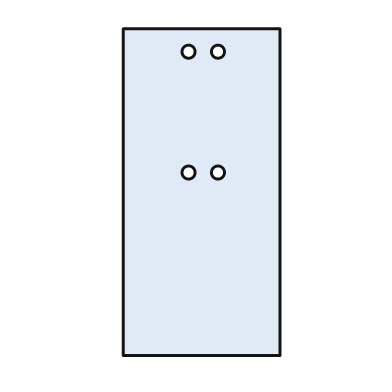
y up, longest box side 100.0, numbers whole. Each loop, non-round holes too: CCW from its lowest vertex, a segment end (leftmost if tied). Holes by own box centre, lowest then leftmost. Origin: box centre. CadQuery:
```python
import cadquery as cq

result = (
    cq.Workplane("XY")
    .moveTo(-24.0, -50.0)
    .lineTo(24.0, -50.0)
    .lineTo(24.0, 50.0)
    .lineTo(-24.0, 50.0)
    .close()
    .moveTo(-4.0, 6.0)
    .circle(2.0)
    .moveTo(5.0, 6.0)
    .circle(2.0)
    .moveTo(-4.0, 43.0)
    .circle(2.0)
    .moveTo(5.0, 43.0)
    .circle(2.0)
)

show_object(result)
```